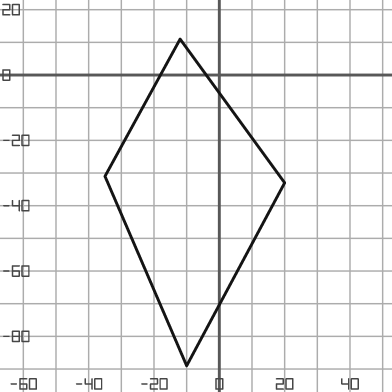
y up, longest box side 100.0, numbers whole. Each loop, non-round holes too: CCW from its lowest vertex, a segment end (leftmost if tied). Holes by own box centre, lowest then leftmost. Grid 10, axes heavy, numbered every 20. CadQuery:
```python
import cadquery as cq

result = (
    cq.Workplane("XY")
    .moveTo(-10.0, -89.0)
    .lineTo(20.0, -33.0)
    .lineTo(-12.0, 11.0)
    .lineTo(-35.0, -31.0)
    .close()
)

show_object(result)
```